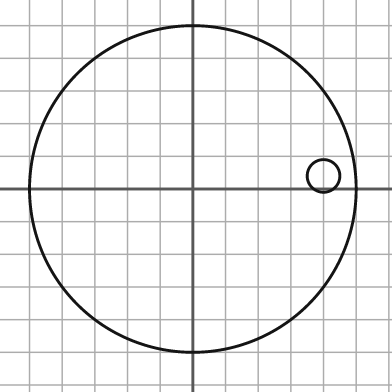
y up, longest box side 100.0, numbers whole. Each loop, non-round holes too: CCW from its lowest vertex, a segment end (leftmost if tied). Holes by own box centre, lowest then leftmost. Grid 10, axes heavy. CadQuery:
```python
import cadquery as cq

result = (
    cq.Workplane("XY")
    .moveTo(0.0, 0.0)
    .circle(50.0)
    .moveTo(40.0, 4.0)
    .circle(5.0)
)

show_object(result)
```